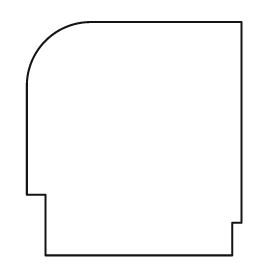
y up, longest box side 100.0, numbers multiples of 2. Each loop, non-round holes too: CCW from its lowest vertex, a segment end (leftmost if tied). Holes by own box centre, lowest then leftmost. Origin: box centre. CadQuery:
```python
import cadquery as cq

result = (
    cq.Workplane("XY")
    .moveTo(-38.0, -50.0)
    .lineTo(42.0, -50.0)
    .lineTo(42.0, -36.0)
    .lineTo(46.0, -36.0)
    .lineTo(46.0, 50.0)
    .lineTo(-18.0, 50.0)
    .threePointArc((-38.0, 42.0), (-46.0, 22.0))
    .lineTo(-46.0, -24.0)
    .lineTo(-38.0, -24.0)
    .close()
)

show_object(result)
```